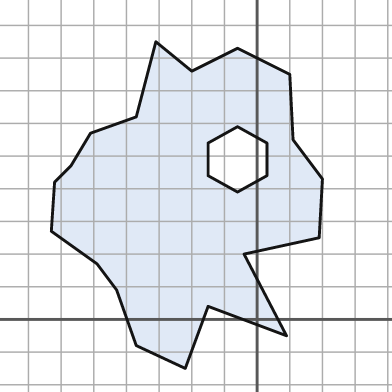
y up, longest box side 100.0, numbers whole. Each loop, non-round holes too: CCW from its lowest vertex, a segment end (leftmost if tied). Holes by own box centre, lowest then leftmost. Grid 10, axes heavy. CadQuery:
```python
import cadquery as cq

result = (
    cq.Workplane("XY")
    .moveTo(-22.0, -15.0)
    .lineTo(-15.0, 4.0)
    .lineTo(9.0, -5.0)
    .lineTo(-4.0, 20.0)
    .lineTo(19.0, 25.0)
    .lineTo(20.0, 43.0)
    .lineTo(11.0, 55.0)
    .lineTo(10.0, 75.0)
    .lineTo(-6.0, 83.0)
    .lineTo(-20.0, 76.0)
    .lineTo(-31.0, 85.0)
    .lineTo(-37.0, 62.0)
    .lineTo(-51.0, 57.0)
    .lineTo(-57.0, 47.0)
    .lineTo(-62.0, 42.0)
    .lineTo(-63.0, 27.0)
    .lineTo(-49.0, 17.0)
    .lineTo(-43.0, 9.0)
    .lineTo(-37.0, -8.0)
    .close()
    .moveTo(-6.0, 39.0)
    .lineTo(3.0, 44.0)
    .lineTo(3.0, 54.0)
    .lineTo(-6.0, 59.0)
    .lineTo(-15.0, 54.0)
    .lineTo(-15.0, 44.0)
    .close()
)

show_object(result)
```